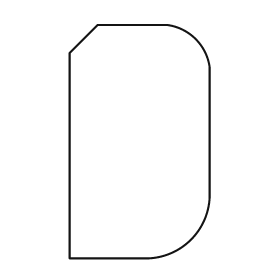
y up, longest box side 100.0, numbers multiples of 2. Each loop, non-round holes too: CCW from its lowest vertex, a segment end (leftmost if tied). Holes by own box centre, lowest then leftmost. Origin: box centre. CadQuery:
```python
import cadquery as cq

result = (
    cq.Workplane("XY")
    .moveTo(-30.0, -50.0)
    .lineTo(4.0, -50.0)
    .threePointArc((22.0, -42.0), (30.0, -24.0))
    .lineTo(30.0, 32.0)
    .threePointArc((24.0, 44.0), (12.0, 50.0))
    .lineTo(-18.0, 50.0)
    .lineTo(-30.0, 38.0)
    .close()
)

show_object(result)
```